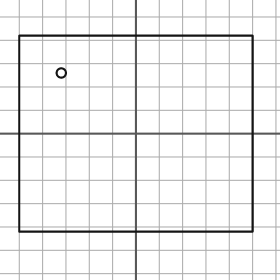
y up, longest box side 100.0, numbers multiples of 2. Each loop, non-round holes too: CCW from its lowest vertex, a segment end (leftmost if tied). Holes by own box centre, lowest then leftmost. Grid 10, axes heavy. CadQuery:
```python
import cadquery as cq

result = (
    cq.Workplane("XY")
    .moveTo(-50.0, -42.0)
    .lineTo(50.0, -42.0)
    .lineTo(50.0, 42.0)
    .lineTo(-50.0, 42.0)
    .close()
    .moveTo(-32.0, 26.0)
    .circle(2.0)
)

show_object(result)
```